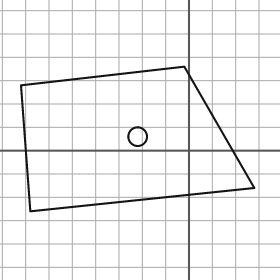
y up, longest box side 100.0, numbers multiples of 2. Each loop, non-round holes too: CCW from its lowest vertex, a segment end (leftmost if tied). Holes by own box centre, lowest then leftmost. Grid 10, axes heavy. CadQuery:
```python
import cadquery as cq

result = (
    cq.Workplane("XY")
    .moveTo(-68.0, -26.0)
    .lineTo(28.0, -16.0)
    .lineTo(-2.0, 36.0)
    .lineTo(-72.0, 28.0)
    .close()
    .moveTo(-22.0, 6.0)
    .circle(4.0)
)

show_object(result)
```